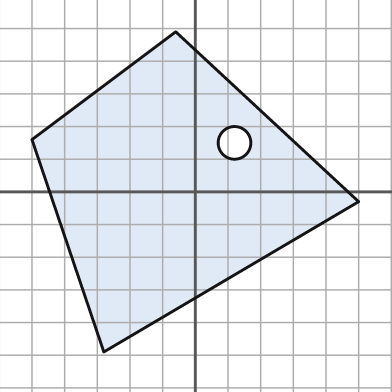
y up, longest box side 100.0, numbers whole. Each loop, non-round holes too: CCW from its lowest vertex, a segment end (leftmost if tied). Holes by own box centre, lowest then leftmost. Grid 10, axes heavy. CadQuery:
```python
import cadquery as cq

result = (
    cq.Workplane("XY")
    .moveTo(-28.0, -49.0)
    .lineTo(50.0, -3.0)
    .lineTo(-6.0, 49.0)
    .lineTo(-50.0, 16.0)
    .close()
    .moveTo(12.0, 15.0)
    .circle(5.0)
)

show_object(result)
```